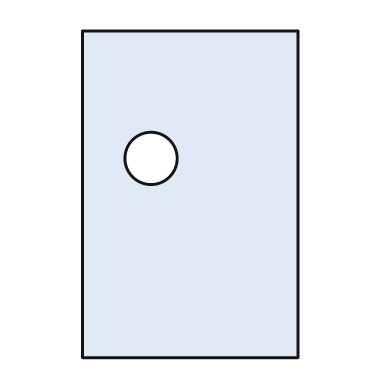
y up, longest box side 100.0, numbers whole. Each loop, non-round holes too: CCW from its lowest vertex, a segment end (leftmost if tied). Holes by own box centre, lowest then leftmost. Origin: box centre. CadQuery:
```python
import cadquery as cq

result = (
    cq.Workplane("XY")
    .moveTo(-33.0, -50.0)
    .lineTo(33.0, -50.0)
    .lineTo(33.0, 50.0)
    .lineTo(-33.0, 50.0)
    .close()
    .moveTo(-12.0, 11.0)
    .circle(8.0)
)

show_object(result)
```